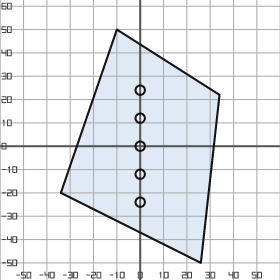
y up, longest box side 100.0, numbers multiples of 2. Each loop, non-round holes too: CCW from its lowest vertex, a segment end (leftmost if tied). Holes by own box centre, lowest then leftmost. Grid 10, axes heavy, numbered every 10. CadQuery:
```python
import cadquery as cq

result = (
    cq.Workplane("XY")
    .moveTo(26.0, -50.0)
    .lineTo(34.0, 22.0)
    .lineTo(-10.0, 50.0)
    .lineTo(-34.0, -20.0)
    .close()
    .moveTo(0.0, -24.0)
    .circle(2.0)
    .moveTo(0.0, -12.0)
    .circle(2.0)
    .moveTo(0.0, 0.0)
    .circle(2.0)
    .moveTo(0.0, 12.0)
    .circle(2.0)
    .moveTo(0.0, 24.0)
    .circle(2.0)
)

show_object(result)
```